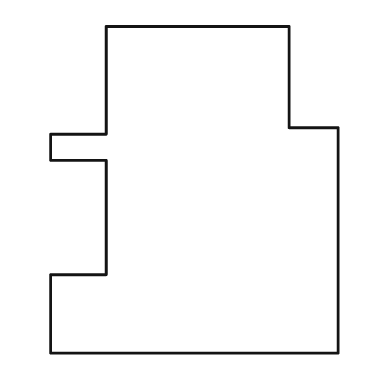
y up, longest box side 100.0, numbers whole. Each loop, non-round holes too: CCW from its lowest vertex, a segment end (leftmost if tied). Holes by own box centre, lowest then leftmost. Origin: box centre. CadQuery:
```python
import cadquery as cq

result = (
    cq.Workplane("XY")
    .moveTo(-44.0, -50.0)
    .lineTo(44.0, -50.0)
    .lineTo(44.0, 19.0)
    .lineTo(29.0, 19.0)
    .lineTo(29.0, 50.0)
    .lineTo(-27.0, 50.0)
    .lineTo(-27.0, 17.0)
    .lineTo(-44.0, 17.0)
    .lineTo(-44.0, 9.0)
    .lineTo(-27.0, 9.0)
    .lineTo(-27.0, -26.0)
    .lineTo(-44.0, -26.0)
    .close()
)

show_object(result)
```